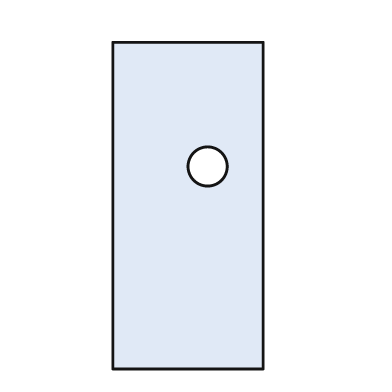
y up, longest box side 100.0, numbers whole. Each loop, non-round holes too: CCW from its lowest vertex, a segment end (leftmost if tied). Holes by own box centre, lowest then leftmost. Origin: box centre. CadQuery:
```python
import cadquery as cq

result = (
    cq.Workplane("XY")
    .moveTo(-23.0, -50.0)
    .lineTo(23.0, -50.0)
    .lineTo(23.0, 50.0)
    .lineTo(-23.0, 50.0)
    .close()
    .moveTo(6.0, 12.0)
    .circle(6.0)
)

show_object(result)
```